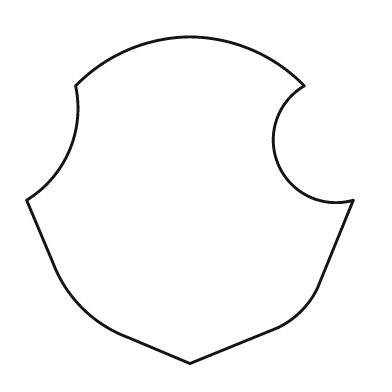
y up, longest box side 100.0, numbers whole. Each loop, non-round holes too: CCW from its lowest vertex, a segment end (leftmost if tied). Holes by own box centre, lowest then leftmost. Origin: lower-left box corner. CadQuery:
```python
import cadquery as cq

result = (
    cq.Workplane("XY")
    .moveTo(50.0, 0.0)
    .lineTo(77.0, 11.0)
    .threePointArc((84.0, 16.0), (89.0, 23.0))
    .lineTo(100.0, 50.0)
    .threePointArc((77.0, 61.0), (85.0, 85.0))
    .threePointArc((69.0, 96.0), (50.0, 100.0))
    .threePointArc((31.0, 96.0), (15.0, 85.0))
    .threePointArc((13.0, 65.0), (0.0, 50.0))
    .lineTo(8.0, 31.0)
    .threePointArc((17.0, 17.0), (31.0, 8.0))
    .close()
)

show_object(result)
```